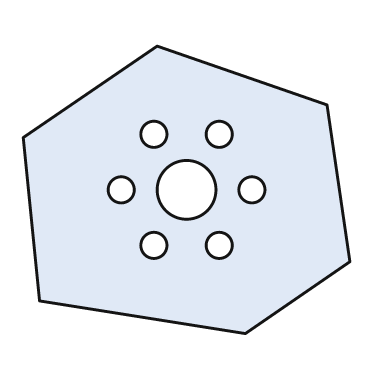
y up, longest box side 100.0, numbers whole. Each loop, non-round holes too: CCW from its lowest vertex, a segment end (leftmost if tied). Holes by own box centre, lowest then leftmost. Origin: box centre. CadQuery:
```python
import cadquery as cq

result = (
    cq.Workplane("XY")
    .moveTo(18.0, -44.0)
    .lineTo(50.0, -22.0)
    .lineTo(43.0, 26.0)
    .lineTo(-9.0, 44.0)
    .lineTo(-50.0, 16.0)
    .lineTo(-45.0, -34.0)
    .close()
    .moveTo(-10.0, -17.0)
    .circle(4.0)
    .moveTo(10.0, -17.0)
    .circle(4.0)
    .moveTo(-20.0, 0.0)
    .circle(4.0)
    .moveTo(0.0, 0.0)
    .circle(9.0)
    .moveTo(20.0, 0.0)
    .circle(4.0)
    .moveTo(-10.0, 17.0)
    .circle(4.0)
    .moveTo(10.0, 17.0)
    .circle(4.0)
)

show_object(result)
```